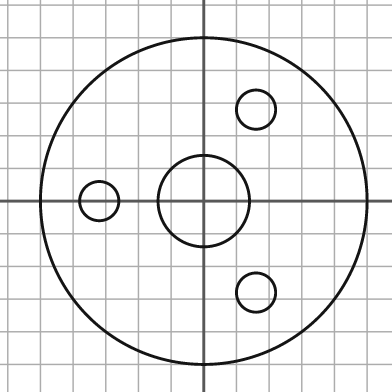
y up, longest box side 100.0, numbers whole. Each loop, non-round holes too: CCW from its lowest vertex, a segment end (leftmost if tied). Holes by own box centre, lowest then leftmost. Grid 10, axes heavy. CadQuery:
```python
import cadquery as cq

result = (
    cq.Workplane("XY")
    .moveTo(0.0, 0.0)
    .circle(50.0)
    .moveTo(16.0, -28.0)
    .circle(6.0)
    .moveTo(-32.0, 0.0)
    .circle(6.0)
    .moveTo(0.0, 0.0)
    .circle(14.0)
    .moveTo(16.0, 28.0)
    .circle(6.0)
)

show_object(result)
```